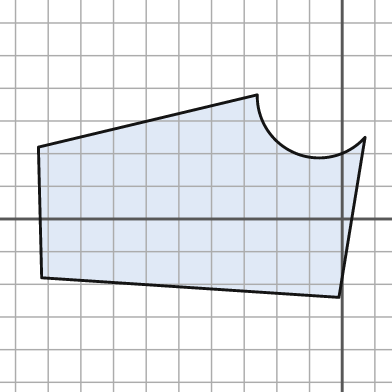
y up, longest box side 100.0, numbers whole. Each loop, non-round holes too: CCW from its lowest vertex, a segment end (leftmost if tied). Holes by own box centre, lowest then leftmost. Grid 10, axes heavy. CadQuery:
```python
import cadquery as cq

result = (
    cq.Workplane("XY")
    .moveTo(-1.0, -24.0)
    .lineTo(7.0, 25.0)
    .threePointArc((-14.0, 20.0), (-26.0, 38.0))
    .lineTo(-93.0, 22.0)
    .lineTo(-92.0, -18.0)
    .close()
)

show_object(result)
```